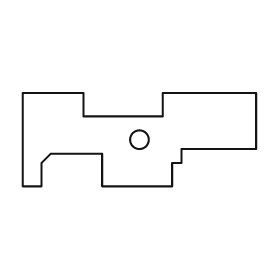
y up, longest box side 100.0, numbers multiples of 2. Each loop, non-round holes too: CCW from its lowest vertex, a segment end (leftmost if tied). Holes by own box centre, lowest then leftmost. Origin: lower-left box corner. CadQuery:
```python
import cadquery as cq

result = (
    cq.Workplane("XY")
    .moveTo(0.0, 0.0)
    .lineTo(8.0, 0.0)
    .lineTo(8.0, 10.0)
    .lineTo(12.0, 14.0)
    .lineTo(34.0, 14.0)
    .lineTo(34.0, 0.0)
    .lineTo(64.0, 0.0)
    .lineTo(64.0, 10.0)
    .lineTo(68.0, 10.0)
    .lineTo(68.0, 16.0)
    .lineTo(100.0, 16.0)
    .lineTo(100.0, 40.0)
    .lineTo(60.0, 40.0)
    .lineTo(60.0, 30.0)
    .lineTo(26.0, 30.0)
    .lineTo(26.0, 40.0)
    .lineTo(0.0, 40.0)
    .close()
    .moveTo(50.0, 20.0)
    .circle(4.0)
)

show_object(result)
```